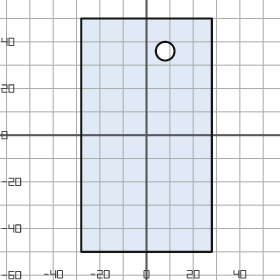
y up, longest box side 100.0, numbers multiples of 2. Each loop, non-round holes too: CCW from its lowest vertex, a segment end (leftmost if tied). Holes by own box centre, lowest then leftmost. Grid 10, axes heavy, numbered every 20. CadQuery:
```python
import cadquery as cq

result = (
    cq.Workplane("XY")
    .moveTo(-28.0, -50.0)
    .lineTo(28.0, -50.0)
    .lineTo(28.0, 50.0)
    .lineTo(-28.0, 50.0)
    .close()
    .moveTo(8.0, 36.0)
    .circle(4.0)
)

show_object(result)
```